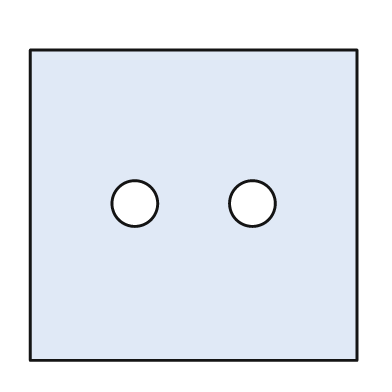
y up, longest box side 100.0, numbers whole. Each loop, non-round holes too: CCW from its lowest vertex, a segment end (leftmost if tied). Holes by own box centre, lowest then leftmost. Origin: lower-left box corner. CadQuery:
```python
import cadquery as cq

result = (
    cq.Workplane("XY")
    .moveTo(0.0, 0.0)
    .lineTo(100.0, 0.0)
    .lineTo(100.0, 95.0)
    .lineTo(0.0, 95.0)
    .close()
    .moveTo(32.0, 48.0)
    .circle(7.0)
    .moveTo(68.0, 48.0)
    .circle(7.0)
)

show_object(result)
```